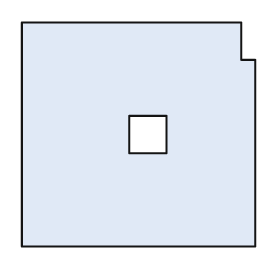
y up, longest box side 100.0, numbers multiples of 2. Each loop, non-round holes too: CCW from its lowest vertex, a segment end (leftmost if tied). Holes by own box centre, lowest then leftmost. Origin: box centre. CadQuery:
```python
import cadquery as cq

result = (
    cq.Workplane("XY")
    .moveTo(-50.0, -48.0)
    .lineTo(50.0, -48.0)
    .lineTo(50.0, 32.0)
    .lineTo(44.0, 32.0)
    .lineTo(44.0, 48.0)
    .lineTo(-50.0, 48.0)
    .close()
    .moveTo(-4.0, -8.0)
    .lineTo(12.0, -8.0)
    .lineTo(12.0, 8.0)
    .lineTo(-4.0, 8.0)
    .close()
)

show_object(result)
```